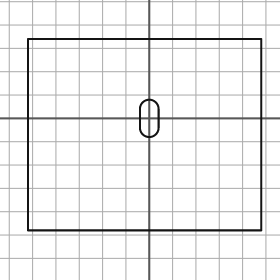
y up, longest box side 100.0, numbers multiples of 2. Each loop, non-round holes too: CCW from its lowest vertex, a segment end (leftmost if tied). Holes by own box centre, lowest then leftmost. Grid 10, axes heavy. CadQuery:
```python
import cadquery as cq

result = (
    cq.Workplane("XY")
    .moveTo(-52.0, -48.0)
    .lineTo(48.0, -48.0)
    .lineTo(48.0, 34.0)
    .lineTo(-52.0, 34.0)
    .close()
    .moveTo(-4.0, -4.0)
    .threePointArc((0.0, -8.0), (4.0, -4.0))
    .lineTo(4.0, 4.0)
    .threePointArc((0.0, 8.0), (-4.0, 4.0))
    .close()
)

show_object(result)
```